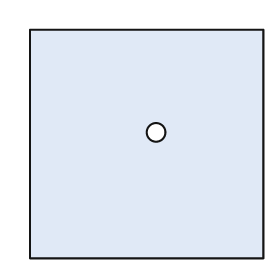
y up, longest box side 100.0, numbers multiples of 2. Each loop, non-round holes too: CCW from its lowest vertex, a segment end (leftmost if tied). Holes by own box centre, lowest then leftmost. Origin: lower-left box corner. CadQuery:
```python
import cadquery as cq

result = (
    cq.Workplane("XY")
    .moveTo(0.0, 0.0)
    .lineTo(100.0, 0.0)
    .lineTo(100.0, 98.0)
    .lineTo(0.0, 98.0)
    .close()
    .moveTo(54.0, 54.0)
    .circle(4.0)
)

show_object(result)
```